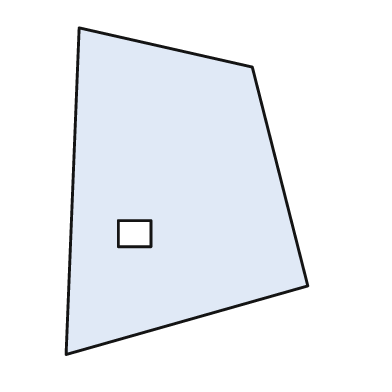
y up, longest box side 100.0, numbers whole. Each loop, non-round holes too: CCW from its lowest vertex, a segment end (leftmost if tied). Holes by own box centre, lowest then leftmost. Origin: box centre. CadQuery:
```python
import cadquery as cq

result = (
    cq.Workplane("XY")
    .moveTo(-37.0, -50.0)
    .lineTo(37.0, -29.0)
    .lineTo(20.0, 38.0)
    .lineTo(-33.0, 50.0)
    .close()
    .moveTo(-21.0, -17.0)
    .lineTo(-11.0, -17.0)
    .lineTo(-11.0, -9.0)
    .lineTo(-21.0, -9.0)
    .close()
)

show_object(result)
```